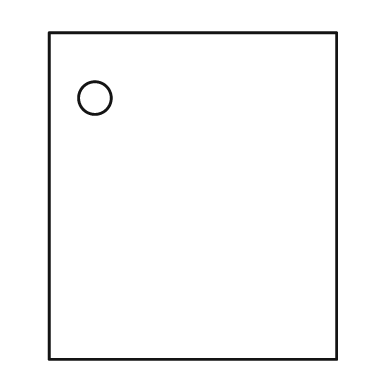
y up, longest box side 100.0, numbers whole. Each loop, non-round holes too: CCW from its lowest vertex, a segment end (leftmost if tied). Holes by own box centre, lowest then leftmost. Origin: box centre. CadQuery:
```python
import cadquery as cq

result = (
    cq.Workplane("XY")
    .moveTo(-44.0, -50.0)
    .lineTo(44.0, -50.0)
    .lineTo(44.0, 50.0)
    .lineTo(-44.0, 50.0)
    .close()
    .moveTo(-30.0, 30.0)
    .circle(5.0)
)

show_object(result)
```